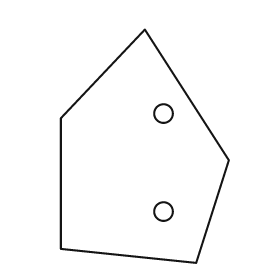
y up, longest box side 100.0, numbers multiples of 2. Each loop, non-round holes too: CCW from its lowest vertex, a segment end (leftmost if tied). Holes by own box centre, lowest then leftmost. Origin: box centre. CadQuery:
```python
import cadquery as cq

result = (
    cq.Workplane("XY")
    .moveTo(22.0, -50.0)
    .lineTo(36.0, -6.0)
    .lineTo(0.0, 50.0)
    .lineTo(-36.0, 12.0)
    .lineTo(-36.0, -44.0)
    .close()
    .moveTo(8.0, -28.0)
    .circle(4.0)
    .moveTo(8.0, 14.0)
    .circle(4.0)
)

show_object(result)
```